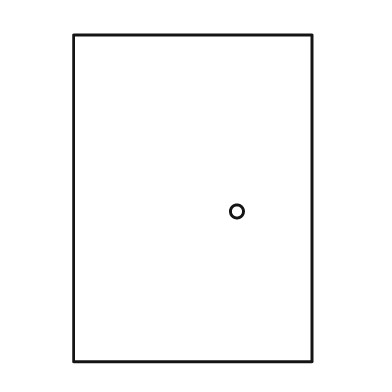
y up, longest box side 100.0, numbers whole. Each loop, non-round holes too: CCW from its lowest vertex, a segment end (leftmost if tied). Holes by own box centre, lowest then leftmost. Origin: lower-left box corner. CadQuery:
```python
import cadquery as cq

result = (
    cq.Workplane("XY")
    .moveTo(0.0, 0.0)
    .lineTo(73.0, 0.0)
    .lineTo(73.0, 100.0)
    .lineTo(0.0, 100.0)
    .close()
    .moveTo(50.0, 46.0)
    .circle(2.0)
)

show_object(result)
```